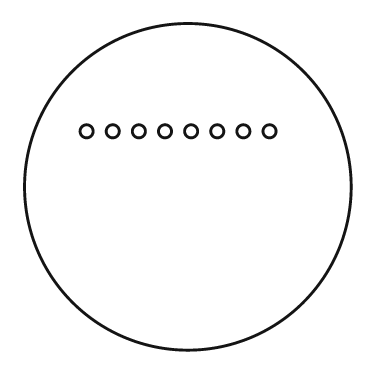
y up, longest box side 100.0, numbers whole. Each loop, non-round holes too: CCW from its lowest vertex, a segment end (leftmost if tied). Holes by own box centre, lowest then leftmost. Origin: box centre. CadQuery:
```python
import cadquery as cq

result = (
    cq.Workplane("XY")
    .moveTo(0.0, 0.0)
    .circle(50.0)
    .moveTo(-31.0, 17.0)
    .circle(2.0)
    .moveTo(-23.0, 17.0)
    .circle(2.0)
    .moveTo(-15.0, 17.0)
    .circle(2.0)
    .moveTo(-7.0, 17.0)
    .circle(2.0)
    .moveTo(1.0, 17.0)
    .circle(2.0)
    .moveTo(9.0, 17.0)
    .circle(2.0)
    .moveTo(17.0, 17.0)
    .circle(2.0)
    .moveTo(25.0, 17.0)
    .circle(2.0)
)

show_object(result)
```